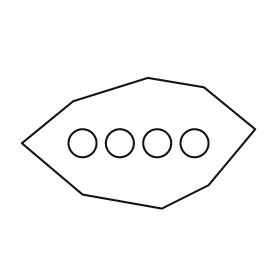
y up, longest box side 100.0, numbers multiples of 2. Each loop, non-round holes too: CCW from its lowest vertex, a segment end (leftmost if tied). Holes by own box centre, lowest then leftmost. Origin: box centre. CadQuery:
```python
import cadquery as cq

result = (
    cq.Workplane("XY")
    .moveTo(10.0, -28.0)
    .lineTo(30.0, -18.0)
    .lineTo(50.0, 6.0)
    .lineTo(28.0, 24.0)
    .lineTo(4.0, 28.0)
    .lineTo(-28.0, 18.0)
    .lineTo(-50.0, 0.0)
    .lineTo(-24.0, -22.0)
    .close()
    .moveTo(-24.0, 0.0)
    .circle(6.0)
    .moveTo(-8.0, 0.0)
    .circle(6.0)
    .moveTo(8.0, 0.0)
    .circle(6.0)
    .moveTo(24.0, 0.0)
    .circle(6.0)
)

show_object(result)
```